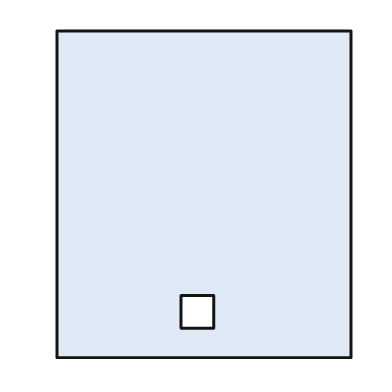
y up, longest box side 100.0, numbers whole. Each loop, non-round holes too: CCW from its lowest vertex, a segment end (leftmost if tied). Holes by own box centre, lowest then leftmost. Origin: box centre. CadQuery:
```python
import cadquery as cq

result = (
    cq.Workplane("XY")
    .moveTo(-45.0, -50.0)
    .lineTo(45.0, -50.0)
    .lineTo(45.0, 50.0)
    .lineTo(-45.0, 50.0)
    .close()
    .moveTo(-7.0, -41.0)
    .lineTo(3.0, -41.0)
    .lineTo(3.0, -31.0)
    .lineTo(-7.0, -31.0)
    .close()
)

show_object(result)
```